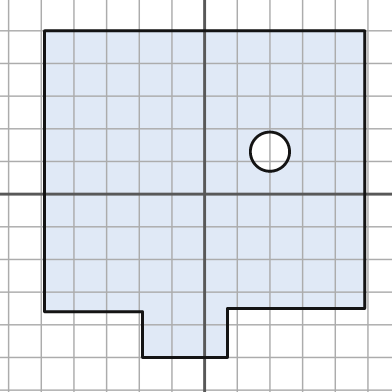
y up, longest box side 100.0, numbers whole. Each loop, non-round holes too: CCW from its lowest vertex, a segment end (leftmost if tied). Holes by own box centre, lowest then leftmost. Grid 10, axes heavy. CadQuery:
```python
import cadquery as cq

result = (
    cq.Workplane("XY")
    .moveTo(-19.0, -50.0)
    .lineTo(7.0, -50.0)
    .lineTo(7.0, -35.0)
    .lineTo(49.0, -35.0)
    .lineTo(49.0, 50.0)
    .lineTo(-49.0, 50.0)
    .lineTo(-49.0, -36.0)
    .lineTo(-19.0, -36.0)
    .close()
    .moveTo(20.0, 13.0)
    .circle(6.0)
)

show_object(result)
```